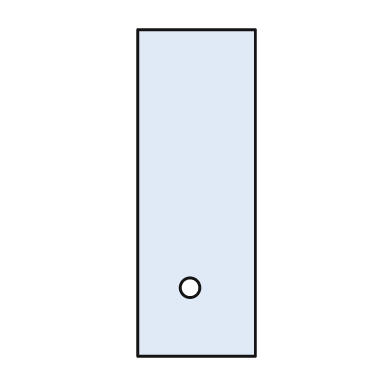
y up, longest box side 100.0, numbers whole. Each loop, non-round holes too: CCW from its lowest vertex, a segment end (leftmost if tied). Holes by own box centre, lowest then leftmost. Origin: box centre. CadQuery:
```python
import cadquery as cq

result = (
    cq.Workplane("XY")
    .moveTo(-18.0, -50.0)
    .lineTo(18.0, -50.0)
    .lineTo(18.0, 50.0)
    .lineTo(-18.0, 50.0)
    .close()
    .moveTo(-2.0, -29.0)
    .circle(3.0)
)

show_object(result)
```